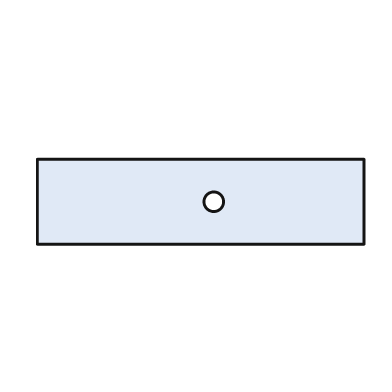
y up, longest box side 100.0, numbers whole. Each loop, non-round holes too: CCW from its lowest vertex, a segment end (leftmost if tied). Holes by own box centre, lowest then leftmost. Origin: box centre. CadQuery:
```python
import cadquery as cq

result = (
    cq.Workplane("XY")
    .moveTo(-50.0, -13.0)
    .lineTo(50.0, -13.0)
    .lineTo(50.0, 13.0)
    .lineTo(-50.0, 13.0)
    .close()
    .moveTo(4.0, 0.0)
    .circle(3.0)
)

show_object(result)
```